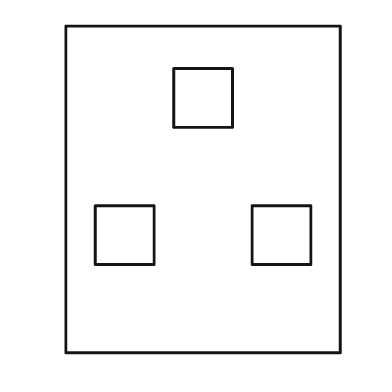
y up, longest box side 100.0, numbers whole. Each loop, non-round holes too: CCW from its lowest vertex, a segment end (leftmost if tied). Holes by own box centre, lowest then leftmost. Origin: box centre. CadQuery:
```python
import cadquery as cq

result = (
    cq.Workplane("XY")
    .moveTo(-42.0, -50.0)
    .lineTo(42.0, -50.0)
    .lineTo(42.0, 50.0)
    .lineTo(-42.0, 50.0)
    .close()
    .moveTo(-33.0, -23.0)
    .lineTo(-15.0, -23.0)
    .lineTo(-15.0, -5.0)
    .lineTo(-33.0, -5.0)
    .close()
    .moveTo(15.0, -23.0)
    .lineTo(33.0, -23.0)
    .lineTo(33.0, -5.0)
    .lineTo(15.0, -5.0)
    .close()
    .moveTo(-9.0, 19.0)
    .lineTo(9.0, 19.0)
    .lineTo(9.0, 37.0)
    .lineTo(-9.0, 37.0)
    .close()
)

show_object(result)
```